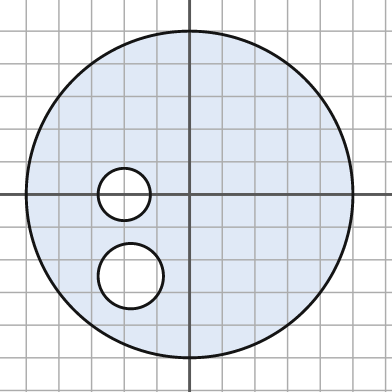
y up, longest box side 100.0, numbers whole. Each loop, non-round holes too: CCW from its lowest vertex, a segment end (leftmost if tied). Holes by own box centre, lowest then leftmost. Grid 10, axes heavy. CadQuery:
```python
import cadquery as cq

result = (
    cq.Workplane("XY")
    .moveTo(0.0, 0.0)
    .circle(50.0)
    .moveTo(-18.0, -25.0)
    .circle(10.0)
    .moveTo(-20.0, 0.0)
    .circle(8.0)
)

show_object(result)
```